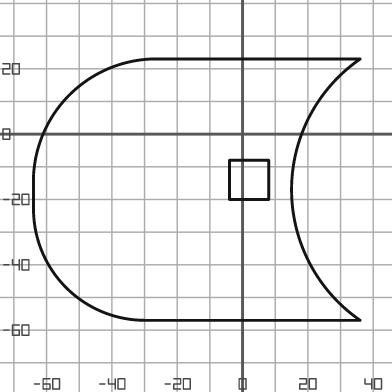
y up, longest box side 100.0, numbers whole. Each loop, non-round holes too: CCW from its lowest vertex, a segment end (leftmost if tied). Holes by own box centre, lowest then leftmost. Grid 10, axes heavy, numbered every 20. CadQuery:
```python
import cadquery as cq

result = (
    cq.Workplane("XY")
    .moveTo(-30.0, -57.0)
    .lineTo(36.0, -57.0)
    .threePointArc((15.0, -17.0), (36.0, 23.0))
    .lineTo(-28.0, 23.0)
    .threePointArc((-53.0, 12.0), (-64.0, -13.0))
    .lineTo(-64.0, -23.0)
    .threePointArc((-54.0, -47.0), (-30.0, -57.0))
    .close()
    .moveTo(-4.0, -20.0)
    .lineTo(8.0, -20.0)
    .lineTo(8.0, -8.0)
    .lineTo(-4.0, -8.0)
    .close()
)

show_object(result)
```